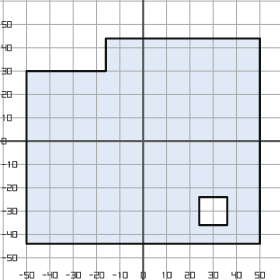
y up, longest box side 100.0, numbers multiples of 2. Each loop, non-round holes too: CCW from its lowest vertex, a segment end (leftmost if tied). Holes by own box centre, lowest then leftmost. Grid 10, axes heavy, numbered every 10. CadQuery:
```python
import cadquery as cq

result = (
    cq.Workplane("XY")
    .moveTo(-50.0, -44.0)
    .lineTo(50.0, -44.0)
    .lineTo(50.0, 44.0)
    .lineTo(-16.0, 44.0)
    .lineTo(-16.0, 30.0)
    .lineTo(-50.0, 30.0)
    .close()
    .moveTo(24.0, -36.0)
    .lineTo(36.0, -36.0)
    .lineTo(36.0, -24.0)
    .lineTo(24.0, -24.0)
    .close()
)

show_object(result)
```